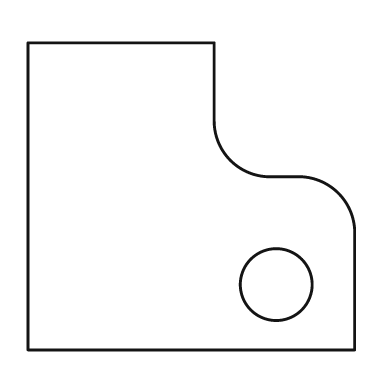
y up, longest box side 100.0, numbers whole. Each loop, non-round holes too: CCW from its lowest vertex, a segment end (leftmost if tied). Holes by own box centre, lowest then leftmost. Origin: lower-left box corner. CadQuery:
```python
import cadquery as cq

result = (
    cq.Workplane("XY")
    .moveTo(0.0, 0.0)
    .lineTo(100.0, 0.0)
    .lineTo(100.0, 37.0)
    .threePointArc((95.0, 48.0), (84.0, 53.0))
    .lineTo(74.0, 53.0)
    .threePointArc((62.0, 58.0), (57.0, 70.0))
    .lineTo(57.0, 94.0)
    .lineTo(0.0, 94.0)
    .close()
    .moveTo(76.0, 20.0)
    .circle(11.0)
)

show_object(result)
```